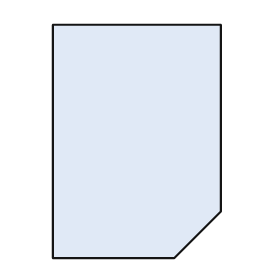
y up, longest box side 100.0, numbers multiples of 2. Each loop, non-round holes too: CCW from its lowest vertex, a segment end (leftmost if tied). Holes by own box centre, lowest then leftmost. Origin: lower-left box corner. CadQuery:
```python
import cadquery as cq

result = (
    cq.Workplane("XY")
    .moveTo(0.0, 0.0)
    .lineTo(52.0, 0.0)
    .lineTo(72.0, 20.0)
    .lineTo(72.0, 100.0)
    .lineTo(0.0, 100.0)
    .close()
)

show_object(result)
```